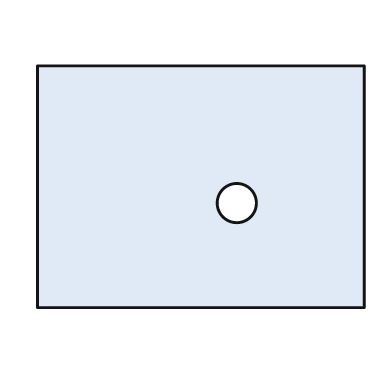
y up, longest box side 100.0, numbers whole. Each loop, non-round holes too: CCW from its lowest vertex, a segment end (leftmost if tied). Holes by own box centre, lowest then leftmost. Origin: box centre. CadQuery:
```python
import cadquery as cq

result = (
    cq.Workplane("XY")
    .moveTo(-50.0, -37.0)
    .lineTo(50.0, -37.0)
    .lineTo(50.0, 37.0)
    .lineTo(-50.0, 37.0)
    .close()
    .moveTo(11.0, -5.0)
    .circle(6.0)
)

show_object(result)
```